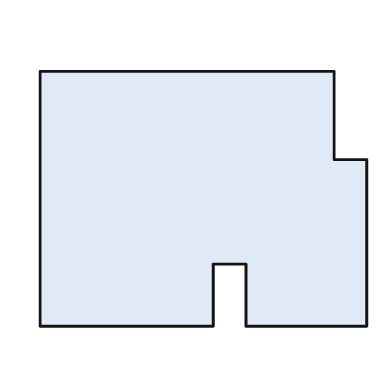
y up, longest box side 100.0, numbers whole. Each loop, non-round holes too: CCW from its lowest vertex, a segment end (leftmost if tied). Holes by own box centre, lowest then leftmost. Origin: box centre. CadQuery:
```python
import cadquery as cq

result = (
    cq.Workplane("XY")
    .moveTo(-50.0, -39.0)
    .lineTo(3.0, -39.0)
    .lineTo(3.0, -20.0)
    .lineTo(13.0, -20.0)
    .lineTo(13.0, -39.0)
    .lineTo(50.0, -39.0)
    .lineTo(50.0, 12.0)
    .lineTo(40.0, 12.0)
    .lineTo(40.0, 39.0)
    .lineTo(-50.0, 39.0)
    .close()
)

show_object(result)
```